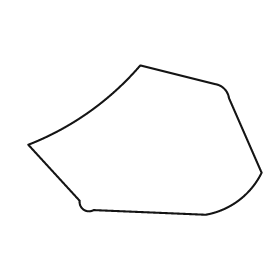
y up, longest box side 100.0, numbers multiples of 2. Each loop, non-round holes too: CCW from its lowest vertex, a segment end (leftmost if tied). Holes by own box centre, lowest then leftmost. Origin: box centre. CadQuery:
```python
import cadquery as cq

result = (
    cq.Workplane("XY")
    .moveTo(26.0, -32.0)
    .threePointArc((40.0, -26.0), (50.0, -14.0))
    .lineTo(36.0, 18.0)
    .threePointArc((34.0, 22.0), (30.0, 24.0))
    .lineTo(-2.0, 32.0)
    .threePointArc((-24.0, 12.0), (-50.0, -2.0))
    .lineTo(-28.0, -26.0)
    .threePointArc((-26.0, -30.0), (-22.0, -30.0))
    .close()
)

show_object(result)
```